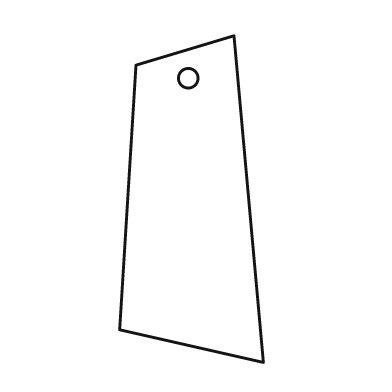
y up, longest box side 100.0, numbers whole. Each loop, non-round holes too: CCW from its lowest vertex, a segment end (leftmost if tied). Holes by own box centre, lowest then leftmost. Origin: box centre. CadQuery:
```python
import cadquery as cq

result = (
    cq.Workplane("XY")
    .moveTo(22.0, -50.0)
    .lineTo(13.0, 50.0)
    .lineTo(-17.0, 41.0)
    .lineTo(-22.0, -40.0)
    .close()
    .moveTo(-1.0, 37.0)
    .circle(3.0)
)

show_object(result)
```